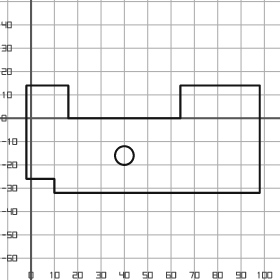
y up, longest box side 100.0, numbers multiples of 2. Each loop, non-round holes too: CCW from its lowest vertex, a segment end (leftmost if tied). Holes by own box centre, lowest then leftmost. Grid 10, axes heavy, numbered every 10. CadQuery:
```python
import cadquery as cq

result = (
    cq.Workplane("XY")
    .moveTo(10.0, -32.0)
    .lineTo(98.0, -32.0)
    .lineTo(98.0, 14.0)
    .lineTo(64.0, 14.0)
    .lineTo(64.0, 0.0)
    .lineTo(16.0, 0.0)
    .lineTo(16.0, 14.0)
    .lineTo(-2.0, 14.0)
    .lineTo(-2.0, -26.0)
    .lineTo(10.0, -26.0)
    .close()
    .moveTo(40.0, -16.0)
    .circle(4.0)
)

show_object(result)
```